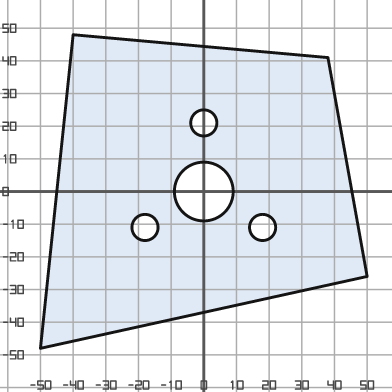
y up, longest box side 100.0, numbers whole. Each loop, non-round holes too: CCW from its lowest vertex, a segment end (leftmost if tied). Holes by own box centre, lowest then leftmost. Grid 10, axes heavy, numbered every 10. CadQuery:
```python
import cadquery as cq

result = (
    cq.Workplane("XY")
    .moveTo(-50.0, -48.0)
    .lineTo(50.0, -26.0)
    .lineTo(38.0, 41.0)
    .lineTo(-40.0, 48.0)
    .close()
    .moveTo(-18.0, -11.0)
    .circle(4.0)
    .moveTo(18.0, -11.0)
    .circle(4.0)
    .moveTo(0.0, 0.0)
    .circle(9.0)
    .moveTo(0.0, 21.0)
    .circle(4.0)
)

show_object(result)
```